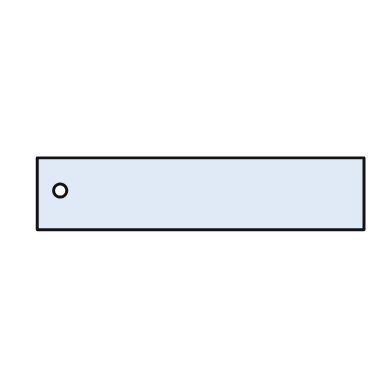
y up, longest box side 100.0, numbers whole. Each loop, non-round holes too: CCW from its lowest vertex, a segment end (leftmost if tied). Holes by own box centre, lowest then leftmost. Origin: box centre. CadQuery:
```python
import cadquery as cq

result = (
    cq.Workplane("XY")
    .moveTo(-50.0, -11.0)
    .lineTo(50.0, -11.0)
    .lineTo(50.0, 11.0)
    .lineTo(-50.0, 11.0)
    .close()
    .moveTo(-43.0, 1.0)
    .circle(2.0)
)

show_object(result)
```